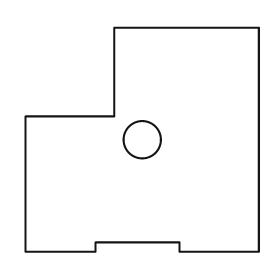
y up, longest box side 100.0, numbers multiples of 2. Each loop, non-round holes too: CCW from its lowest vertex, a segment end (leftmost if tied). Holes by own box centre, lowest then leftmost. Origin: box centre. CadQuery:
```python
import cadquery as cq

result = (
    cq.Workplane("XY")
    .moveTo(-50.0, -48.0)
    .lineTo(-20.0, -48.0)
    .lineTo(-20.0, -44.0)
    .lineTo(16.0, -44.0)
    .lineTo(16.0, -48.0)
    .lineTo(50.0, -48.0)
    .lineTo(50.0, 48.0)
    .lineTo(-12.0, 48.0)
    .lineTo(-12.0, 10.0)
    .lineTo(-50.0, 10.0)
    .close()
    .moveTo(0.0, 0.0)
    .circle(8.0)
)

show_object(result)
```